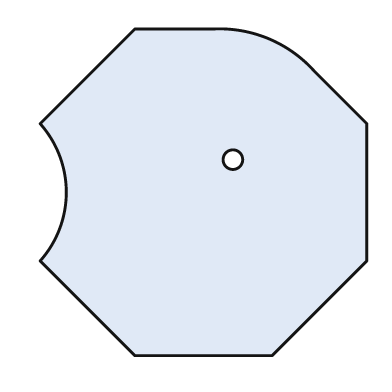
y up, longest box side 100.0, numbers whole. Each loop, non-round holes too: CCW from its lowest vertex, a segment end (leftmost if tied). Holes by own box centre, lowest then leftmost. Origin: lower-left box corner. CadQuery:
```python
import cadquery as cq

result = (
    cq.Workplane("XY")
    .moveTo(29.0, 0.0)
    .lineTo(71.0, 0.0)
    .lineTo(100.0, 29.0)
    .lineTo(100.0, 71.0)
    .lineTo(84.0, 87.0)
    .threePointArc((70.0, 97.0), (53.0, 100.0))
    .lineTo(29.0, 100.0)
    .lineTo(0.0, 71.0)
    .threePointArc((8.0, 50.0), (0.0, 29.0))
    .close()
    .moveTo(59.0, 60.0)
    .circle(3.0)
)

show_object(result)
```